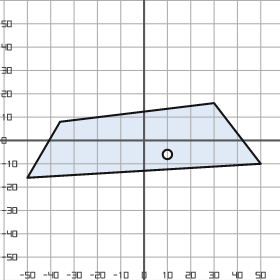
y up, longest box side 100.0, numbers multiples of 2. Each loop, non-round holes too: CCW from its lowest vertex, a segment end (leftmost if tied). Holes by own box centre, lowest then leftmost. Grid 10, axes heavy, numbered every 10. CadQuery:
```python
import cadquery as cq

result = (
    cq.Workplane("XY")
    .moveTo(-50.0, -16.0)
    .lineTo(50.0, -10.0)
    .lineTo(30.0, 16.0)
    .lineTo(-36.0, 8.0)
    .close()
    .moveTo(10.0, -6.0)
    .circle(2.0)
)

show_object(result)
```